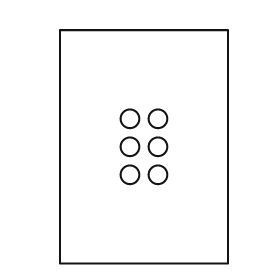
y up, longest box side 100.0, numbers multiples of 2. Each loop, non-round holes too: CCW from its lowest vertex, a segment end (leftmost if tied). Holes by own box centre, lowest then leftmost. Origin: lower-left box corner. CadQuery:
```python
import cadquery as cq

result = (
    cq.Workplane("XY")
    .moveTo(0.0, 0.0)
    .lineTo(72.0, 0.0)
    .lineTo(72.0, 100.0)
    .lineTo(0.0, 100.0)
    .close()
    .moveTo(30.0, 38.0)
    .circle(4.0)
    .moveTo(42.0, 38.0)
    .circle(4.0)
    .moveTo(30.0, 50.0)
    .circle(4.0)
    .moveTo(42.0, 50.0)
    .circle(4.0)
    .moveTo(30.0, 62.0)
    .circle(4.0)
    .moveTo(42.0, 62.0)
    .circle(4.0)
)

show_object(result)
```